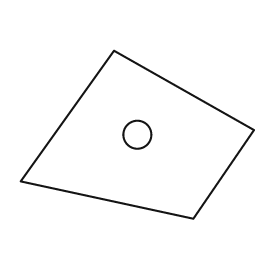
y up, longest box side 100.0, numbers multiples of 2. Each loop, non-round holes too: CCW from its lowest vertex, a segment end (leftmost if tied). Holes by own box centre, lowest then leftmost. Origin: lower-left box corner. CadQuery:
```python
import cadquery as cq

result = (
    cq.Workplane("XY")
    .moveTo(74.0, 0.0)
    .lineTo(100.0, 38.0)
    .lineTo(40.0, 72.0)
    .lineTo(0.0, 16.0)
    .close()
    .moveTo(50.0, 36.0)
    .circle(6.0)
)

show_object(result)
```